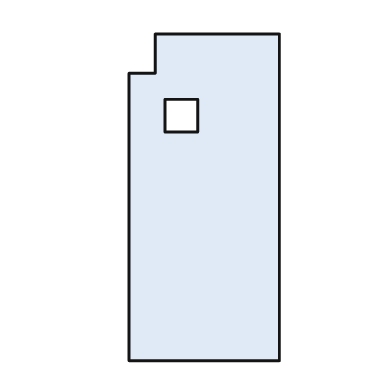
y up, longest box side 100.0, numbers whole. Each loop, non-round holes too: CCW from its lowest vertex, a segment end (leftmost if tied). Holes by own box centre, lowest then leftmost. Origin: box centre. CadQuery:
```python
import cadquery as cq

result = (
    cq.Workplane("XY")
    .moveTo(-23.0, -50.0)
    .lineTo(23.0, -50.0)
    .lineTo(23.0, 50.0)
    .lineTo(-15.0, 50.0)
    .lineTo(-15.0, 38.0)
    .lineTo(-23.0, 38.0)
    .close()
    .moveTo(-12.0, 20.0)
    .lineTo(-2.0, 20.0)
    .lineTo(-2.0, 30.0)
    .lineTo(-12.0, 30.0)
    .close()
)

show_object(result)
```